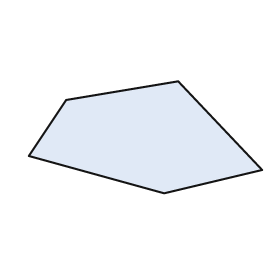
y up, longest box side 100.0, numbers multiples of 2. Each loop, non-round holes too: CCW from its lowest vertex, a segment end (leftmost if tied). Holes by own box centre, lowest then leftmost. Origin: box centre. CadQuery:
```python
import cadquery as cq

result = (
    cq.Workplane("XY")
    .moveTo(8.0, -24.0)
    .lineTo(50.0, -14.0)
    .lineTo(14.0, 24.0)
    .lineTo(-34.0, 16.0)
    .lineTo(-50.0, -8.0)
    .close()
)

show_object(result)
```